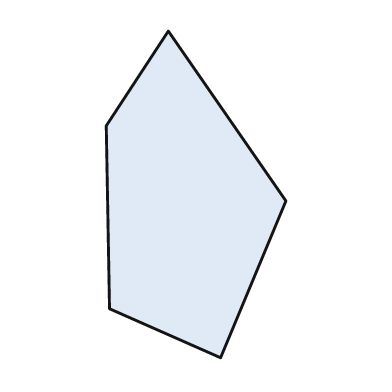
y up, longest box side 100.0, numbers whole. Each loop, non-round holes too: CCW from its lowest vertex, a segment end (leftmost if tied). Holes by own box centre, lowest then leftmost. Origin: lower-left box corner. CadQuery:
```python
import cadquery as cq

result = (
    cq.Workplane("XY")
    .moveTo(35.0, 0.0)
    .lineTo(55.0, 48.0)
    .lineTo(19.0, 100.0)
    .lineTo(0.0, 71.0)
    .lineTo(1.0, 15.0)
    .close()
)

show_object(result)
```